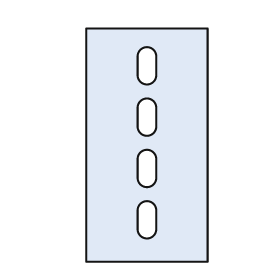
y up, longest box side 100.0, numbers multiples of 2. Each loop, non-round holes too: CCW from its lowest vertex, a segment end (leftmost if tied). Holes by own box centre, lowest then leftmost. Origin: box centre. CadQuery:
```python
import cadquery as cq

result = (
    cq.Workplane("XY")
    .moveTo(-26.0, -50.0)
    .lineTo(26.0, -50.0)
    .lineTo(26.0, 50.0)
    .lineTo(-26.0, 50.0)
    .close()
    .moveTo(-4.0, -36.0)
    .threePointArc((0.0, -40.0), (4.0, -36.0))
    .lineTo(4.0, -28.0)
    .threePointArc((0.0, -24.0), (-4.0, -28.0))
    .close()
    .moveTo(-4.0, -14.0)
    .threePointArc((0.0, -18.0), (4.0, -14.0))
    .lineTo(4.0, -6.0)
    .threePointArc((0.0, -2.0), (-4.0, -6.0))
    .close()
    .moveTo(-4.0, 8.0)
    .threePointArc((0.0, 4.0), (4.0, 8.0))
    .lineTo(4.0, 16.0)
    .threePointArc((0.0, 20.0), (-4.0, 16.0))
    .close()
    .moveTo(-4.0, 30.0)
    .threePointArc((0.0, 26.0), (4.0, 30.0))
    .lineTo(4.0, 38.0)
    .threePointArc((0.0, 42.0), (-4.0, 38.0))
    .close()
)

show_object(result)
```